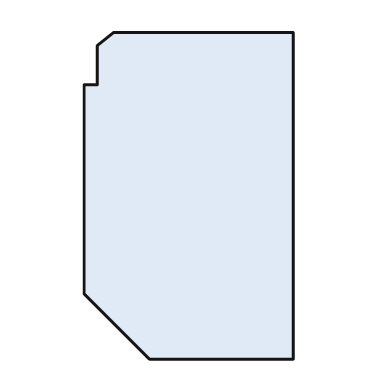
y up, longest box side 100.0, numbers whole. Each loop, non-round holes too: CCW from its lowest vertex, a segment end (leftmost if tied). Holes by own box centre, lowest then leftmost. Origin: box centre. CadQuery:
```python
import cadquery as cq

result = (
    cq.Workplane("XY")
    .moveTo(-12.0, -50.0)
    .lineTo(32.0, -50.0)
    .lineTo(32.0, 50.0)
    .lineTo(-23.0, 50.0)
    .lineTo(-28.0, 46.0)
    .lineTo(-28.0, 34.0)
    .lineTo(-32.0, 34.0)
    .lineTo(-32.0, -30.0)
    .close()
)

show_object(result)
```